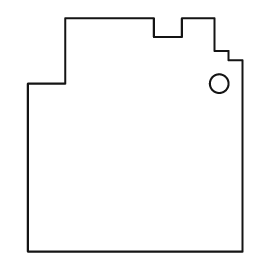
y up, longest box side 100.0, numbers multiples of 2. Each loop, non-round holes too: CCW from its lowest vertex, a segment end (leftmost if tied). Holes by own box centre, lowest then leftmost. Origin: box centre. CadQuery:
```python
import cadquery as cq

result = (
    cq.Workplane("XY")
    .moveTo(-46.0, -50.0)
    .lineTo(46.0, -50.0)
    .lineTo(46.0, 32.0)
    .lineTo(40.0, 32.0)
    .lineTo(40.0, 36.0)
    .lineTo(34.0, 36.0)
    .lineTo(34.0, 50.0)
    .lineTo(20.0, 50.0)
    .lineTo(20.0, 42.0)
    .lineTo(8.0, 42.0)
    .lineTo(8.0, 50.0)
    .lineTo(-30.0, 50.0)
    .lineTo(-30.0, 22.0)
    .lineTo(-46.0, 22.0)
    .close()
    .moveTo(36.0, 22.0)
    .circle(4.0)
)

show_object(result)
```